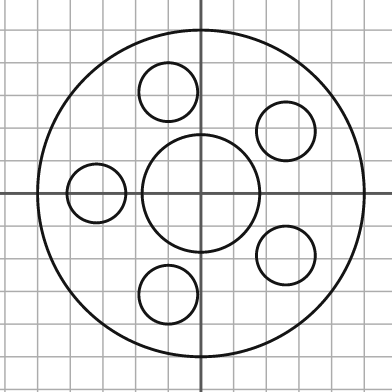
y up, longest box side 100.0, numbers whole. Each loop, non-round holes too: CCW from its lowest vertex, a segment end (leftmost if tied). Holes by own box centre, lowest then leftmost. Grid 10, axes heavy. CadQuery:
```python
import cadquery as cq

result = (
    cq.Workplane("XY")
    .moveTo(0.0, 0.0)
    .circle(50.0)
    .moveTo(-10.0, -31.0)
    .circle(9.0)
    .moveTo(26.0, -19.0)
    .circle(9.0)
    .moveTo(-32.0, 0.0)
    .circle(9.0)
    .moveTo(0.0, 0.0)
    .circle(18.0)
    .moveTo(26.0, 19.0)
    .circle(9.0)
    .moveTo(-10.0, 31.0)
    .circle(9.0)
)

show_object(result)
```